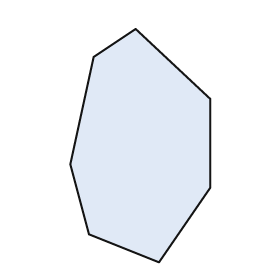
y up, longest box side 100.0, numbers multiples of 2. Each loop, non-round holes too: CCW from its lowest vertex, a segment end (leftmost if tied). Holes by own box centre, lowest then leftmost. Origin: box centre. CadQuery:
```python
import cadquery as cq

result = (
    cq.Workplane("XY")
    .moveTo(8.0, -50.0)
    .lineTo(30.0, -18.0)
    .lineTo(30.0, 20.0)
    .lineTo(-2.0, 50.0)
    .lineTo(-20.0, 38.0)
    .lineTo(-30.0, -8.0)
    .lineTo(-22.0, -38.0)
    .close()
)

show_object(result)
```